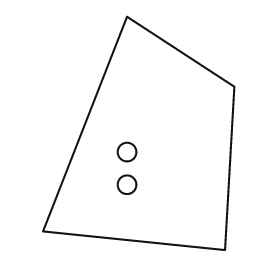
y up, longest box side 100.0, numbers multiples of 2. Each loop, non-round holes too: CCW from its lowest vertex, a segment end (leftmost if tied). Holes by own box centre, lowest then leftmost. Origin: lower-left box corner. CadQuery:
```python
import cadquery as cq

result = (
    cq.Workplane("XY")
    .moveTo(78.0, 0.0)
    .lineTo(82.0, 70.0)
    .lineTo(36.0, 100.0)
    .lineTo(0.0, 8.0)
    .close()
    .moveTo(36.0, 28.0)
    .circle(4.0)
    .moveTo(36.0, 42.0)
    .circle(4.0)
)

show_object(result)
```